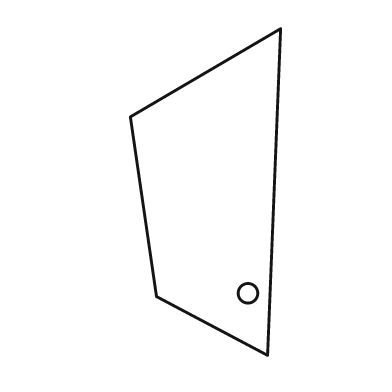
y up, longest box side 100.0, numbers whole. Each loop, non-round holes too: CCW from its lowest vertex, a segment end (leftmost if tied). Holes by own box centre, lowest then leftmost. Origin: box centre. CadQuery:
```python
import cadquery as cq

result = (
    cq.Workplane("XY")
    .moveTo(19.0, -50.0)
    .lineTo(23.0, 50.0)
    .lineTo(-23.0, 23.0)
    .lineTo(-15.0, -32.0)
    .close()
    .moveTo(13.0, -31.0)
    .circle(3.0)
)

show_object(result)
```